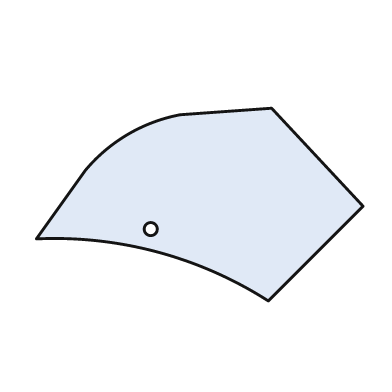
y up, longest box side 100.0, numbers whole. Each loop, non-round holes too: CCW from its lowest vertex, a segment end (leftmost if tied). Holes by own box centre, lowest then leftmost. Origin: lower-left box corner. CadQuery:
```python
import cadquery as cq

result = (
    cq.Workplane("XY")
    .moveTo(71.0, 0.0)
    .lineTo(100.0, 29.0)
    .lineTo(72.0, 59.0)
    .lineTo(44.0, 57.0)
    .threePointArc((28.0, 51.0), (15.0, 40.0))
    .lineTo(0.0, 19.0)
    .threePointArc((37.0, 15.0), (71.0, 0.0))
    .close()
    .moveTo(35.0, 22.0)
    .circle(2.0)
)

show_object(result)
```